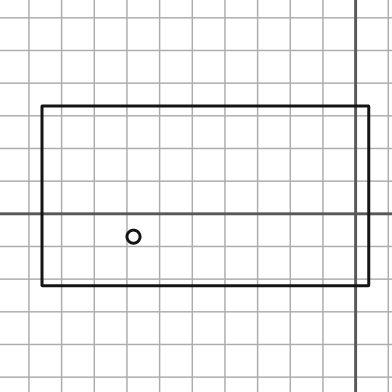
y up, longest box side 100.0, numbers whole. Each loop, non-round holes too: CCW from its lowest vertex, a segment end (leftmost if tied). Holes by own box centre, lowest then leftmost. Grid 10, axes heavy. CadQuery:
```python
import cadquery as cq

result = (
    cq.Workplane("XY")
    .moveTo(-96.0, -22.0)
    .lineTo(4.0, -22.0)
    .lineTo(4.0, 33.0)
    .lineTo(-96.0, 33.0)
    .close()
    .moveTo(-68.0, -7.0)
    .circle(2.0)
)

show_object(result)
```